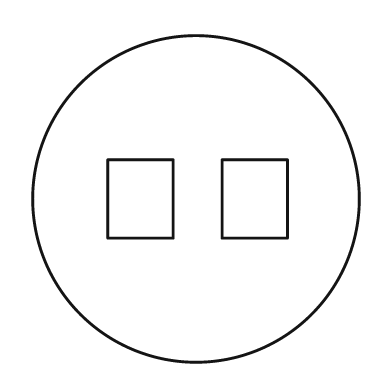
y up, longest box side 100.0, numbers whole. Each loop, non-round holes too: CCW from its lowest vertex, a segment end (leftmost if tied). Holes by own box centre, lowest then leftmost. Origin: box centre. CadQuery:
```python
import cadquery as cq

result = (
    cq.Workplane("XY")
    .moveTo(0.0, 0.0)
    .circle(50.0)
    .moveTo(-27.0, -12.0)
    .lineTo(-7.0, -12.0)
    .lineTo(-7.0, 12.0)
    .lineTo(-27.0, 12.0)
    .close()
    .moveTo(8.0, -12.0)
    .lineTo(28.0, -12.0)
    .lineTo(28.0, 12.0)
    .lineTo(8.0, 12.0)
    .close()
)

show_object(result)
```